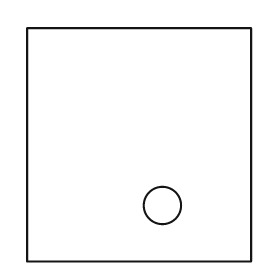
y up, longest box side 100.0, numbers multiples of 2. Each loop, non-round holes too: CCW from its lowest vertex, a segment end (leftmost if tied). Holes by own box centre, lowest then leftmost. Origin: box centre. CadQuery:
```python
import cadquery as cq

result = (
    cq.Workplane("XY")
    .moveTo(-48.0, -50.0)
    .lineTo(48.0, -50.0)
    .lineTo(48.0, 50.0)
    .lineTo(-48.0, 50.0)
    .close()
    .moveTo(10.0, -26.0)
    .circle(8.0)
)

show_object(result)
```